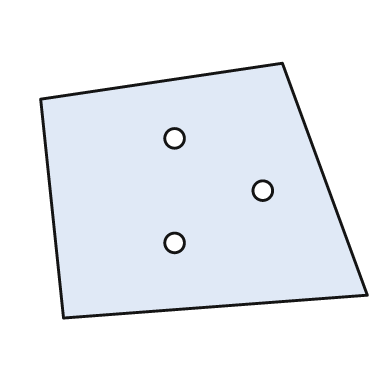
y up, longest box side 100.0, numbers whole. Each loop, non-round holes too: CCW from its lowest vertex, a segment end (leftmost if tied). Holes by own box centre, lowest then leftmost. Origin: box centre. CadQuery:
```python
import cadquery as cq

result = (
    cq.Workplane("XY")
    .moveTo(-43.0, -39.0)
    .lineTo(50.0, -32.0)
    .lineTo(24.0, 39.0)
    .lineTo(-50.0, 28.0)
    .close()
    .moveTo(-9.0, -16.0)
    .circle(3.0)
    .moveTo(18.0, 0.0)
    .circle(3.0)
    .moveTo(-9.0, 16.0)
    .circle(3.0)
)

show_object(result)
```